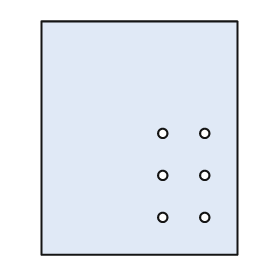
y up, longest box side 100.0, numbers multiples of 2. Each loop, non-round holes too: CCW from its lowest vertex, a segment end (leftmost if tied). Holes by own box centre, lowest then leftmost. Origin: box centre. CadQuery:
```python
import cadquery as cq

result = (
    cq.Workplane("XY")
    .moveTo(-42.0, -50.0)
    .lineTo(42.0, -50.0)
    .lineTo(42.0, 50.0)
    .lineTo(-42.0, 50.0)
    .close()
    .moveTo(10.0, -34.0)
    .circle(2.0)
    .moveTo(28.0, -34.0)
    .circle(2.0)
    .moveTo(10.0, -16.0)
    .circle(2.0)
    .moveTo(28.0, -16.0)
    .circle(2.0)
    .moveTo(10.0, 2.0)
    .circle(2.0)
    .moveTo(28.0, 2.0)
    .circle(2.0)
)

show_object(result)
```